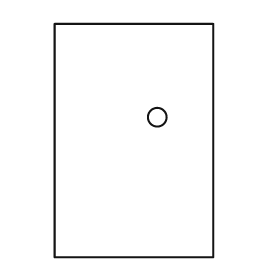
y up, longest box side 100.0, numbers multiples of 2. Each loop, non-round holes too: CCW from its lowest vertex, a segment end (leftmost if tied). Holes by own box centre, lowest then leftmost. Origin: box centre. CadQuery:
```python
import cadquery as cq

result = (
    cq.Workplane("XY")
    .moveTo(-34.0, -50.0)
    .lineTo(34.0, -50.0)
    .lineTo(34.0, 50.0)
    .lineTo(-34.0, 50.0)
    .close()
    .moveTo(10.0, 10.0)
    .circle(4.0)
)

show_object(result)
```